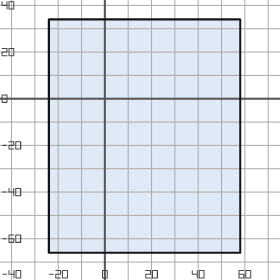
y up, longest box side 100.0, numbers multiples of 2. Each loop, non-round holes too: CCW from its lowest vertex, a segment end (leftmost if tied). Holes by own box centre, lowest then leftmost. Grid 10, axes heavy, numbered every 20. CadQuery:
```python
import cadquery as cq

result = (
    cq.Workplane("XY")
    .moveTo(-24.0, -66.0)
    .lineTo(58.0, -66.0)
    .lineTo(58.0, 34.0)
    .lineTo(-24.0, 34.0)
    .close()
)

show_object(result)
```